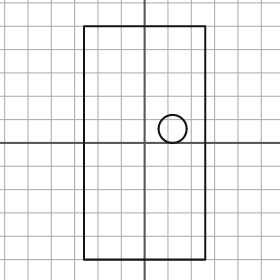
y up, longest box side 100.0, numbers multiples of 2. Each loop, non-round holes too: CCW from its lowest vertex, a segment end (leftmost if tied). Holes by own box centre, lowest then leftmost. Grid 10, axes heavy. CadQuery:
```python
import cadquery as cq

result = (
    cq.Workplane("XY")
    .moveTo(-26.0, -50.0)
    .lineTo(26.0, -50.0)
    .lineTo(26.0, 50.0)
    .lineTo(-26.0, 50.0)
    .close()
    .moveTo(12.0, 6.0)
    .circle(6.0)
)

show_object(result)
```